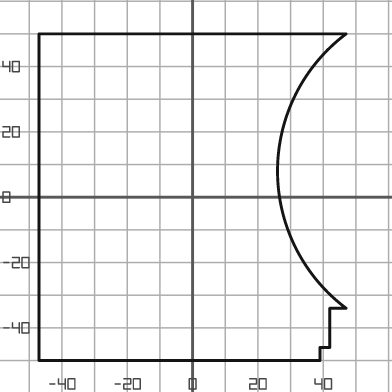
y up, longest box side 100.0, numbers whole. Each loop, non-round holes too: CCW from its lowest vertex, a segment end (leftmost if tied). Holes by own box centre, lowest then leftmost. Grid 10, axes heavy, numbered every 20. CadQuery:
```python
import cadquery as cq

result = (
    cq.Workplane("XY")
    .moveTo(-47.0, -50.0)
    .lineTo(39.0, -50.0)
    .lineTo(39.0, -46.0)
    .lineTo(42.0, -46.0)
    .lineTo(42.0, -34.0)
    .lineTo(47.0, -34.0)
    .threePointArc((26.0, 8.0), (47.0, 50.0))
    .lineTo(-47.0, 50.0)
    .close()
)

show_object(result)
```